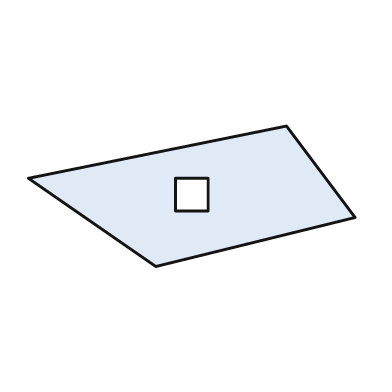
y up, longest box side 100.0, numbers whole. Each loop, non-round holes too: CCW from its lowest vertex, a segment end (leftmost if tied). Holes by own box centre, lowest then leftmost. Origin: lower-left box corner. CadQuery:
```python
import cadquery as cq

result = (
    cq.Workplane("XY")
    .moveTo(39.0, 0.0)
    .lineTo(100.0, 15.0)
    .lineTo(79.0, 43.0)
    .lineTo(0.0, 27.0)
    .close()
    .moveTo(45.0, 17.0)
    .lineTo(55.0, 17.0)
    .lineTo(55.0, 27.0)
    .lineTo(45.0, 27.0)
    .close()
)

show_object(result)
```